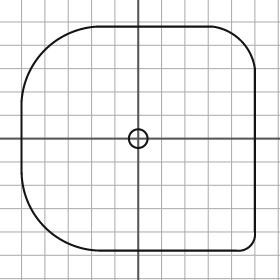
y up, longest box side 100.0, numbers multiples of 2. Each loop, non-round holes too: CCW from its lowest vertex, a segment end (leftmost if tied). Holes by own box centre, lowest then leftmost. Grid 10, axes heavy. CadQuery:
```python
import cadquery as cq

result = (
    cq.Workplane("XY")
    .moveTo(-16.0, -48.0)
    .lineTo(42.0, -48.0)
    .threePointArc((48.0, -46.0), (50.0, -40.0))
    .lineTo(50.0, 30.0)
    .threePointArc((44.0, 42.0), (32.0, 48.0))
    .lineTo(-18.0, 48.0)
    .threePointArc((-40.0, 38.0), (-50.0, 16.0))
    .lineTo(-50.0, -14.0)
    .threePointArc((-40.0, -38.0), (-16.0, -48.0))
    .close()
    .moveTo(0.0, 0.0)
    .circle(4.0)
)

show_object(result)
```